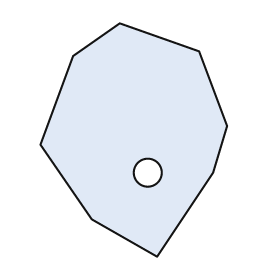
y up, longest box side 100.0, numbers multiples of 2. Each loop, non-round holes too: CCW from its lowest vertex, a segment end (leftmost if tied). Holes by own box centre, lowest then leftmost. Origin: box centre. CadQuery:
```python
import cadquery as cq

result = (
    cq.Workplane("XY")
    .moveTo(10.0, -50.0)
    .lineTo(34.0, -14.0)
    .lineTo(40.0, 6.0)
    .lineTo(28.0, 38.0)
    .lineTo(-6.0, 50.0)
    .lineTo(-26.0, 36.0)
    .lineTo(-40.0, -2.0)
    .lineTo(-18.0, -34.0)
    .close()
    .moveTo(6.0, -14.0)
    .circle(6.0)
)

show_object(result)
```